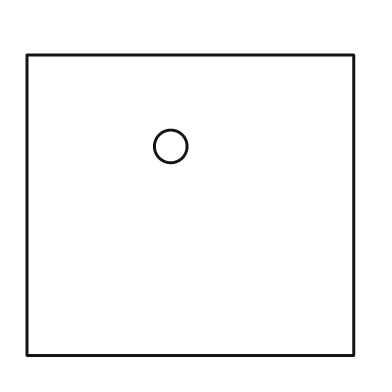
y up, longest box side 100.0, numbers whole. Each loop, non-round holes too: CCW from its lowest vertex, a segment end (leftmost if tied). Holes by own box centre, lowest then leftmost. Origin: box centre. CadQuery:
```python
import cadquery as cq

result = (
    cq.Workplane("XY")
    .moveTo(-50.0, -46.0)
    .lineTo(50.0, -46.0)
    .lineTo(50.0, 46.0)
    .lineTo(-50.0, 46.0)
    .close()
    .moveTo(-6.0, 18.0)
    .circle(5.0)
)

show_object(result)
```